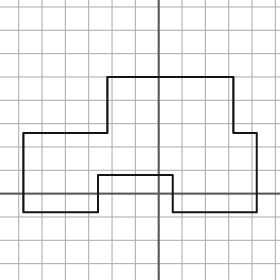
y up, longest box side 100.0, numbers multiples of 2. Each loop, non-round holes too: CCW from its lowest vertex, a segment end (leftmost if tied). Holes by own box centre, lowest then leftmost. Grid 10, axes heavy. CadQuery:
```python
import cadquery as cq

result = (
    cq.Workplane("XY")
    .moveTo(-58.0, -8.0)
    .lineTo(-26.0, -8.0)
    .lineTo(-26.0, 8.0)
    .lineTo(6.0, 8.0)
    .lineTo(6.0, -8.0)
    .lineTo(42.0, -8.0)
    .lineTo(42.0, 26.0)
    .lineTo(32.0, 26.0)
    .lineTo(32.0, 50.0)
    .lineTo(-22.0, 50.0)
    .lineTo(-22.0, 26.0)
    .lineTo(-58.0, 26.0)
    .close()
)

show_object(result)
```